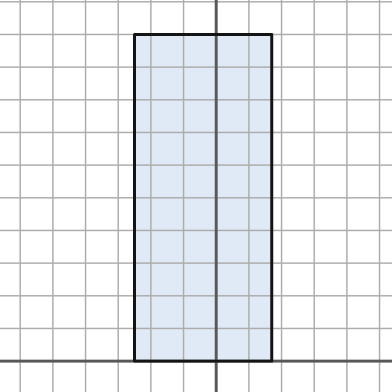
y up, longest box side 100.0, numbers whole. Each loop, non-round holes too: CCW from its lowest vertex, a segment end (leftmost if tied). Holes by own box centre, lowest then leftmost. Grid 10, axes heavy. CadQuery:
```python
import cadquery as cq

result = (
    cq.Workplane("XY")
    .moveTo(-25.0, 0.0)
    .lineTo(17.0, 0.0)
    .lineTo(17.0, 100.0)
    .lineTo(-25.0, 100.0)
    .close()
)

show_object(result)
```